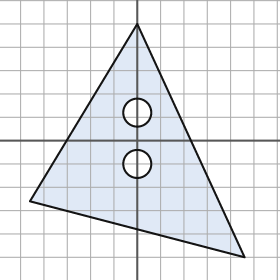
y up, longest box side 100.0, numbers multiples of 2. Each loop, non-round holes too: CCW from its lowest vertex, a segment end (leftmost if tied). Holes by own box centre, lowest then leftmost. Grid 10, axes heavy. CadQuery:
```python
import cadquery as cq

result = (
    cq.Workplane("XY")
    .moveTo(46.0, -50.0)
    .lineTo(0.0, 50.0)
    .lineTo(-46.0, -26.0)
    .close()
    .moveTo(0.0, -10.0)
    .circle(6.0)
    .moveTo(0.0, 12.0)
    .circle(6.0)
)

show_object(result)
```